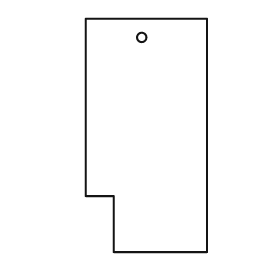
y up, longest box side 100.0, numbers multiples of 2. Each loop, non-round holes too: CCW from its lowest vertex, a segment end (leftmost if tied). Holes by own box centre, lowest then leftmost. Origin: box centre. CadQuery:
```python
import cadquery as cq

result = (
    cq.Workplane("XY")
    .moveTo(-14.0, -50.0)
    .lineTo(26.0, -50.0)
    .lineTo(26.0, 50.0)
    .lineTo(-26.0, 50.0)
    .lineTo(-26.0, -26.0)
    .lineTo(-14.0, -26.0)
    .close()
    .moveTo(-2.0, 42.0)
    .circle(2.0)
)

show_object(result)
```